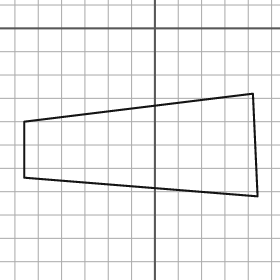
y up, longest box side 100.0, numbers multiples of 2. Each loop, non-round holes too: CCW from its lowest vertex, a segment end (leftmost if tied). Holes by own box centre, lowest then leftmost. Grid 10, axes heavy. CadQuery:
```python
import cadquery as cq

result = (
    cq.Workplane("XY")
    .moveTo(44.0, -72.0)
    .lineTo(42.0, -28.0)
    .lineTo(-56.0, -40.0)
    .lineTo(-56.0, -64.0)
    .close()
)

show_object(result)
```